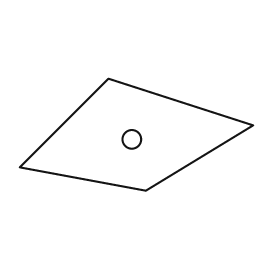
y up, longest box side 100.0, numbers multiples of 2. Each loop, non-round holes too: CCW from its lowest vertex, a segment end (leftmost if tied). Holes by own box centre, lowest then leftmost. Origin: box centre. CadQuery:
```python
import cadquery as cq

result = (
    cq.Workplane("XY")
    .moveTo(4.0, -24.0)
    .lineTo(50.0, 4.0)
    .lineTo(-12.0, 24.0)
    .lineTo(-50.0, -14.0)
    .close()
    .moveTo(-2.0, -2.0)
    .circle(4.0)
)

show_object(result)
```